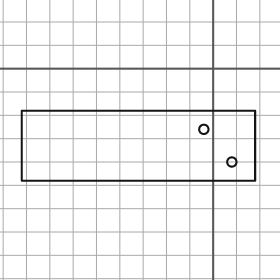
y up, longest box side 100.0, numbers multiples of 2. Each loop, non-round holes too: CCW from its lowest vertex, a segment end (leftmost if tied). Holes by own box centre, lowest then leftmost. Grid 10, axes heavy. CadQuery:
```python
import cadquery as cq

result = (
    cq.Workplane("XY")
    .moveTo(-82.0, -48.0)
    .lineTo(18.0, -48.0)
    .lineTo(18.0, -18.0)
    .lineTo(-82.0, -18.0)
    .close()
    .moveTo(8.0, -40.0)
    .circle(2.0)
    .moveTo(-4.0, -26.0)
    .circle(2.0)
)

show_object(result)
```